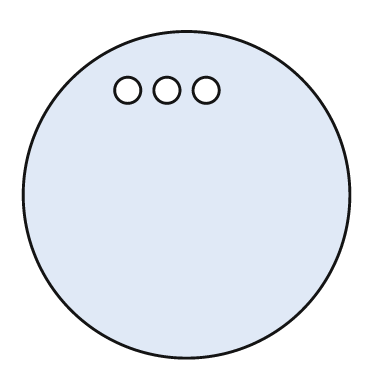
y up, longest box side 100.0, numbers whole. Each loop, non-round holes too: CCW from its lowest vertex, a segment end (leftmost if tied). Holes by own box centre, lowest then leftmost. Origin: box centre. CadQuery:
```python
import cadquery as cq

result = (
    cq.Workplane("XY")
    .moveTo(0.0, 0.0)
    .circle(50.0)
    .moveTo(-18.0, 32.0)
    .circle(4.0)
    .moveTo(-6.0, 32.0)
    .circle(4.0)
    .moveTo(6.0, 32.0)
    .circle(4.0)
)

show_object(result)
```